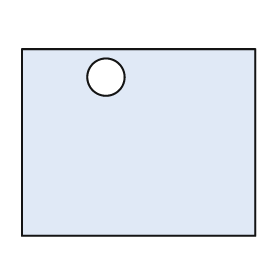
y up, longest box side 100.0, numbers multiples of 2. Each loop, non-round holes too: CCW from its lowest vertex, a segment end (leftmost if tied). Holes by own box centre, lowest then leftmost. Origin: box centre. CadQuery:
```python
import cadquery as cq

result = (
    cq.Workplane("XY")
    .moveTo(-50.0, -40.0)
    .lineTo(50.0, -40.0)
    .lineTo(50.0, 40.0)
    .lineTo(-50.0, 40.0)
    .close()
    .moveTo(-14.0, 28.0)
    .circle(8.0)
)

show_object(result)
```